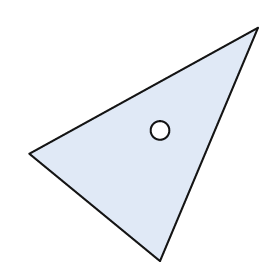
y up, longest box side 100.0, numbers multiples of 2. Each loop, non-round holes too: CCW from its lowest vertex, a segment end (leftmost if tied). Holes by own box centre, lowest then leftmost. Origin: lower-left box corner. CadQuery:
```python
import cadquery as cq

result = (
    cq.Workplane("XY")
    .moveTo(56.0, 0.0)
    .lineTo(98.0, 100.0)
    .lineTo(0.0, 46.0)
    .close()
    .moveTo(56.0, 56.0)
    .circle(4.0)
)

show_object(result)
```